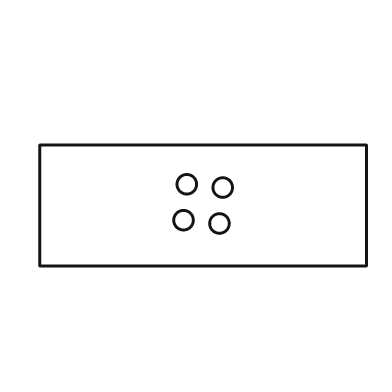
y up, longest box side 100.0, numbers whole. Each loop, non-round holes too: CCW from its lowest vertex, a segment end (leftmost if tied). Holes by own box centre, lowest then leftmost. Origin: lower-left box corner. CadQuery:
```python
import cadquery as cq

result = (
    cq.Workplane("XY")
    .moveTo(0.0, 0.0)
    .lineTo(100.0, 0.0)
    .lineTo(100.0, 37.0)
    .lineTo(0.0, 37.0)
    .close()
    .moveTo(55.0, 13.0)
    .circle(3.0)
    .moveTo(44.0, 14.0)
    .circle(3.0)
    .moveTo(56.0, 24.0)
    .circle(3.0)
    .moveTo(45.0, 25.0)
    .circle(3.0)
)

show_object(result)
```